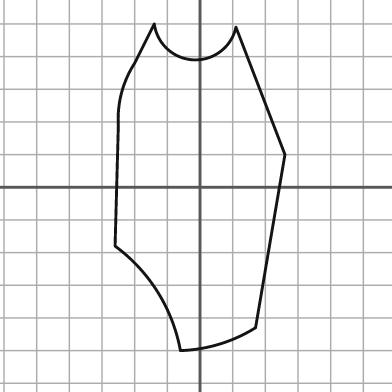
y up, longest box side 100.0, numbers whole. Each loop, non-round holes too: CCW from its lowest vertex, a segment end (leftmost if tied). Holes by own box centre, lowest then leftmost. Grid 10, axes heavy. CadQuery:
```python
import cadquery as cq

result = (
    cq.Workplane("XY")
    .moveTo(-6.0, -50.0)
    .threePointArc((6.0, -48.0), (17.0, -43.0))
    .lineTo(26.0, 10.0)
    .lineTo(11.0, 49.0)
    .threePointArc((-2.0, 39.0), (-14.0, 50.0))
    .lineTo(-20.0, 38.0)
    .threePointArc((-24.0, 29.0), (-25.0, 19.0))
    .lineTo(-26.0, -18.0)
    .threePointArc((-13.0, -32.0), (-6.0, -50.0))
    .close()
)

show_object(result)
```